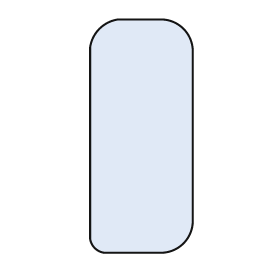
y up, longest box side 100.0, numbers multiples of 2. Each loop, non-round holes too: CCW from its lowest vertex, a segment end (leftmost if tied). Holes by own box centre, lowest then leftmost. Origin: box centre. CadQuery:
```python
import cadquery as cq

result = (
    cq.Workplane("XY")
    .moveTo(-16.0, -50.0)
    .lineTo(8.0, -50.0)
    .threePointArc((18.0, -46.0), (22.0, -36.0))
    .lineTo(22.0, 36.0)
    .threePointArc((18.0, 46.0), (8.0, 50.0))
    .lineTo(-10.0, 50.0)
    .threePointArc((-18.0, 46.0), (-22.0, 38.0))
    .lineTo(-22.0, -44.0)
    .threePointArc((-20.0, -48.0), (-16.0, -50.0))
    .close()
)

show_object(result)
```